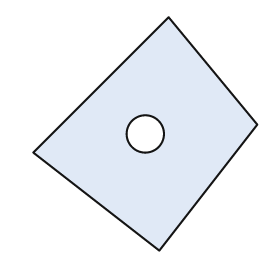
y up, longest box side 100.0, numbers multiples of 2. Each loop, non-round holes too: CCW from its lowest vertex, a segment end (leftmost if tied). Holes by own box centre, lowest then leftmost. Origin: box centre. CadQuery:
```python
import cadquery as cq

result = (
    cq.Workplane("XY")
    .moveTo(6.0, -50.0)
    .lineTo(48.0, 4.0)
    .lineTo(10.0, 50.0)
    .lineTo(-48.0, -8.0)
    .close()
    .moveTo(0.0, 0.0)
    .circle(8.0)
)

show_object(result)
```